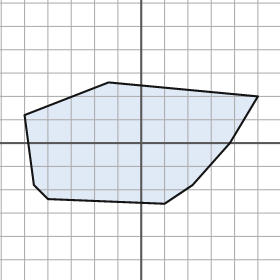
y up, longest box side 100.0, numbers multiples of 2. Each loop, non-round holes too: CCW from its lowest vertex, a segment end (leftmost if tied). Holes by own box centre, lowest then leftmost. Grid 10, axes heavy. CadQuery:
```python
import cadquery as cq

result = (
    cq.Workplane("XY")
    .moveTo(10.0, -26.0)
    .lineTo(22.0, -18.0)
    .lineTo(38.0, 0.0)
    .lineTo(50.0, 20.0)
    .lineTo(-14.0, 26.0)
    .lineTo(-50.0, 12.0)
    .lineTo(-46.0, -18.0)
    .lineTo(-40.0, -24.0)
    .close()
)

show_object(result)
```